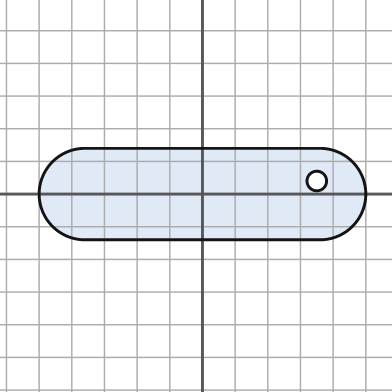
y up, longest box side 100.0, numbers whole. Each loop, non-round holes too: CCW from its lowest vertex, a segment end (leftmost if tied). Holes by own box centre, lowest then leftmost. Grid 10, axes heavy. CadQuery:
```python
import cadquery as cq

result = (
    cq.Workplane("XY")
    .moveTo(-36.0, -14.0)
    .lineTo(36.0, -14.0)
    .threePointArc((50.0, 0.0), (36.0, 14.0))
    .lineTo(-36.0, 14.0)
    .threePointArc((-50.0, 0.0), (-36.0, -14.0))
    .close()
    .moveTo(35.0, 4.0)
    .circle(3.0)
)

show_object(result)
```